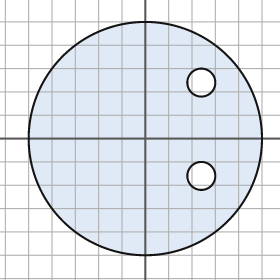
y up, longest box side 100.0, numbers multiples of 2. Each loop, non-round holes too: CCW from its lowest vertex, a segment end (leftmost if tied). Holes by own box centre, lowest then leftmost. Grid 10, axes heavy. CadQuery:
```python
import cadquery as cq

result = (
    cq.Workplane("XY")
    .moveTo(0.0, 0.0)
    .circle(50.0)
    .moveTo(24.0, -16.0)
    .circle(6.0)
    .moveTo(24.0, 24.0)
    .circle(6.0)
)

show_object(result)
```